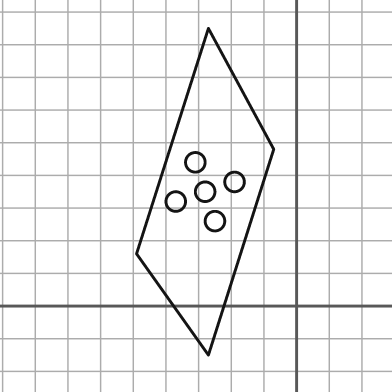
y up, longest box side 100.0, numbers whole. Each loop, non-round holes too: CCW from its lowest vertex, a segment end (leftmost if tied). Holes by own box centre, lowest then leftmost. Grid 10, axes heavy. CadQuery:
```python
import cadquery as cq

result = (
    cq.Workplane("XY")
    .moveTo(-27.0, -15.0)
    .lineTo(-7.0, 48.0)
    .lineTo(-27.0, 85.0)
    .lineTo(-49.0, 16.0)
    .close()
    .moveTo(-25.0, 26.0)
    .circle(3.0)
    .moveTo(-37.0, 32.0)
    .circle(3.0)
    .moveTo(-28.0, 35.0)
    .circle(3.0)
    .moveTo(-19.0, 38.0)
    .circle(3.0)
    .moveTo(-31.0, 44.0)
    .circle(3.0)
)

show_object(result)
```